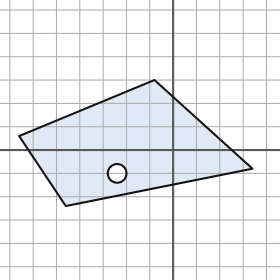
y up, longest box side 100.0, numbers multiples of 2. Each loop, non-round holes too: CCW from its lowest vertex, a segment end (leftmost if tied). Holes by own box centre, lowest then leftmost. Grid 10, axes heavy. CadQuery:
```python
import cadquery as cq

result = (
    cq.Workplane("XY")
    .moveTo(-46.0, -24.0)
    .lineTo(34.0, -8.0)
    .lineTo(-8.0, 30.0)
    .lineTo(-66.0, 6.0)
    .close()
    .moveTo(-24.0, -10.0)
    .circle(4.0)
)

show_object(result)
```